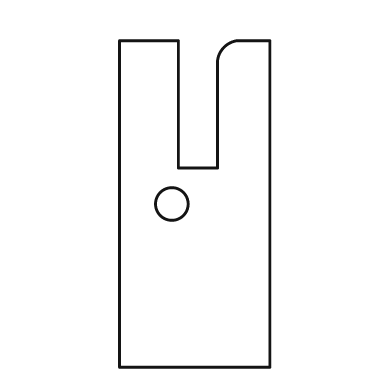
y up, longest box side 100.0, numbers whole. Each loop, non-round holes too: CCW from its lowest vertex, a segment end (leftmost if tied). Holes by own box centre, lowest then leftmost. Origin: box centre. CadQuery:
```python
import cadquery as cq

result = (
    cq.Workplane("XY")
    .moveTo(-23.0, -50.0)
    .lineTo(23.0, -50.0)
    .lineTo(23.0, 50.0)
    .lineTo(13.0, 50.0)
    .threePointArc((9.0, 48.0), (7.0, 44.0))
    .lineTo(7.0, 11.0)
    .lineTo(-5.0, 11.0)
    .lineTo(-5.0, 50.0)
    .lineTo(-23.0, 50.0)
    .close()
    .moveTo(-7.0, 0.0)
    .circle(5.0)
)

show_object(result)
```